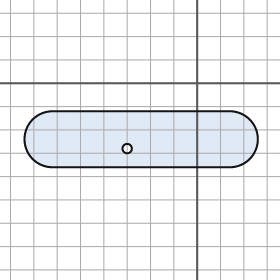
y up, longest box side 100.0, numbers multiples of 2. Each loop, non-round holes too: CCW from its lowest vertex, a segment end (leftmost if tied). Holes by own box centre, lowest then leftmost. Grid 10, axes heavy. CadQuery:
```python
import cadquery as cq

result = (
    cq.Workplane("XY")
    .moveTo(-62.0, -36.0)
    .lineTo(14.0, -36.0)
    .threePointArc((26.0, -24.0), (14.0, -12.0))
    .lineTo(-62.0, -12.0)
    .threePointArc((-74.0, -24.0), (-62.0, -36.0))
    .close()
    .moveTo(-30.0, -28.0)
    .circle(2.0)
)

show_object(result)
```